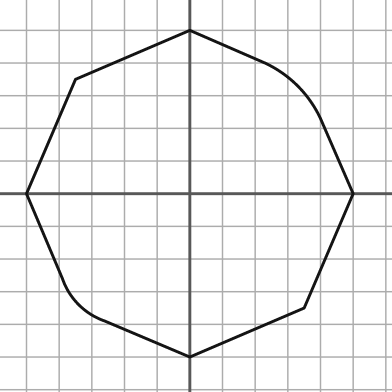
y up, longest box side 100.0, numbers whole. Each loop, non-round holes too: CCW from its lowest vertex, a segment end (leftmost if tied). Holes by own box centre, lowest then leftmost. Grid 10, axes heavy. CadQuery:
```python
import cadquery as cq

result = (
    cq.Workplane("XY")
    .moveTo(0.0, -50.0)
    .lineTo(35.0, -35.0)
    .lineTo(50.0, 0.0)
    .lineTo(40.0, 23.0)
    .threePointArc((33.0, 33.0), (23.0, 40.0))
    .lineTo(0.0, 50.0)
    .lineTo(-35.0, 35.0)
    .lineTo(-50.0, 0.0)
    .lineTo(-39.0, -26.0)
    .threePointArc((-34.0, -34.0), (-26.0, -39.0))
    .close()
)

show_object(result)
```